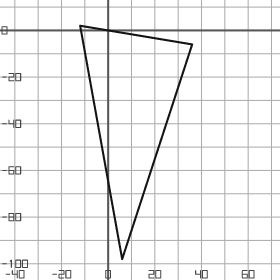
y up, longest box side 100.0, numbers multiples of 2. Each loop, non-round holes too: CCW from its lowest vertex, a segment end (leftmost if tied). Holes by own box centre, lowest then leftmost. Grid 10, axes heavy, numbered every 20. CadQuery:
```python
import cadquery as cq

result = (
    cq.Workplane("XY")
    .moveTo(6.0, -98.0)
    .lineTo(36.0, -6.0)
    .lineTo(-12.0, 2.0)
    .close()
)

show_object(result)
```